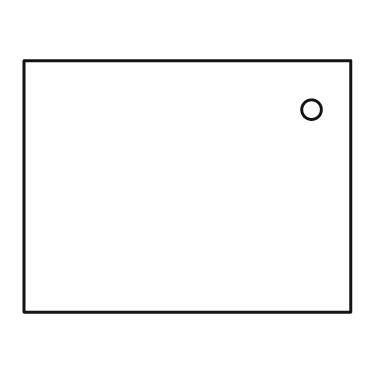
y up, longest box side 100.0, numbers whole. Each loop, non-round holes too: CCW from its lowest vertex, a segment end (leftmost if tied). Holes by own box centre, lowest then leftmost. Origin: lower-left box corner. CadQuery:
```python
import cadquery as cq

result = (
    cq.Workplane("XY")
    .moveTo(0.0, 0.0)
    .lineTo(100.0, 0.0)
    .lineTo(100.0, 77.0)
    .lineTo(0.0, 77.0)
    .close()
    .moveTo(88.0, 62.0)
    .circle(3.0)
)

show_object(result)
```